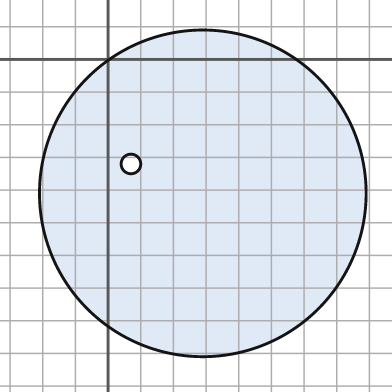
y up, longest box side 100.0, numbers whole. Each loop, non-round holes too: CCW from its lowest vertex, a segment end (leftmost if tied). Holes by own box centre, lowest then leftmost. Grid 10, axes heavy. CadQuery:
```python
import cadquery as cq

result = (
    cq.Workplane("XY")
    .moveTo(29.0, -41.0)
    .circle(50.0)
    .moveTo(7.0, -32.0)
    .circle(3.0)
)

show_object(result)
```